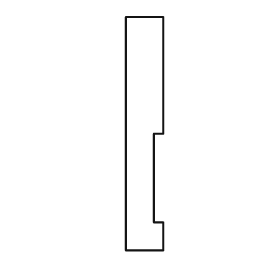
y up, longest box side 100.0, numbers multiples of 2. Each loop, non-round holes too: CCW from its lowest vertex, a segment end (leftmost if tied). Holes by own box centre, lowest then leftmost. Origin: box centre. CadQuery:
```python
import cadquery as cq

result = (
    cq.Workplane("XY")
    .moveTo(-8.0, -50.0)
    .lineTo(8.0, -50.0)
    .lineTo(8.0, -38.0)
    .lineTo(4.0, -38.0)
    .lineTo(4.0, 0.0)
    .lineTo(8.0, 0.0)
    .lineTo(8.0, 50.0)
    .lineTo(-8.0, 50.0)
    .close()
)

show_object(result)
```